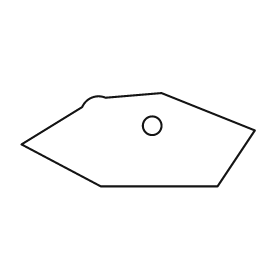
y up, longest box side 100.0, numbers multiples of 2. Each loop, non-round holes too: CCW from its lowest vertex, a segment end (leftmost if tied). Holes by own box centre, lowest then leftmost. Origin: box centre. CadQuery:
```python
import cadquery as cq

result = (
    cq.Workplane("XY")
    .moveTo(-16.0, -20.0)
    .lineTo(34.0, -20.0)
    .lineTo(50.0, 4.0)
    .lineTo(10.0, 20.0)
    .lineTo(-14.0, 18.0)
    .threePointArc((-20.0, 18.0), (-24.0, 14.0))
    .lineTo(-50.0, -2.0)
    .close()
    .moveTo(6.0, 6.0)
    .circle(4.0)
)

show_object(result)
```